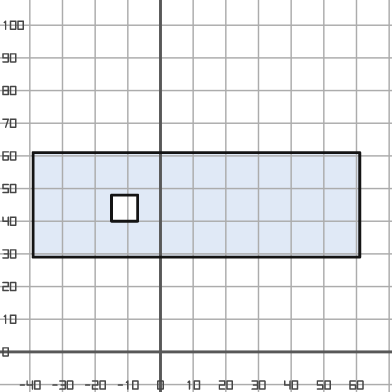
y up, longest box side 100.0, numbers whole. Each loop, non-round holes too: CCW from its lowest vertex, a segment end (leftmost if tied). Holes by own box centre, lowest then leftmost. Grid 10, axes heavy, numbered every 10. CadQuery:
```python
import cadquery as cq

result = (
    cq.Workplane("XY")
    .moveTo(-39.0, 29.0)
    .lineTo(61.0, 29.0)
    .lineTo(61.0, 61.0)
    .lineTo(-39.0, 61.0)
    .close()
    .moveTo(-15.0, 40.0)
    .lineTo(-7.0, 40.0)
    .lineTo(-7.0, 48.0)
    .lineTo(-15.0, 48.0)
    .close()
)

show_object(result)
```